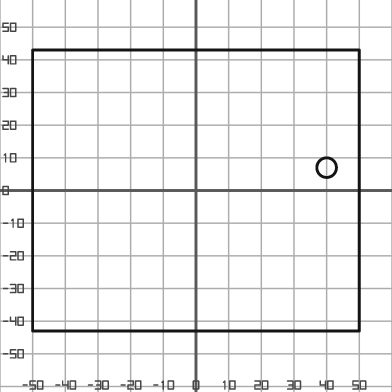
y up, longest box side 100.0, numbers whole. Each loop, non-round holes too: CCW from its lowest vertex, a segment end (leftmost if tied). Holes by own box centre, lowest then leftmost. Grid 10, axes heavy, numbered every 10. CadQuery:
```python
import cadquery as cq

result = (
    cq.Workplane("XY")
    .moveTo(-50.0, -43.0)
    .lineTo(50.0, -43.0)
    .lineTo(50.0, 43.0)
    .lineTo(-50.0, 43.0)
    .close()
    .moveTo(40.0, 7.0)
    .circle(3.0)
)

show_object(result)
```